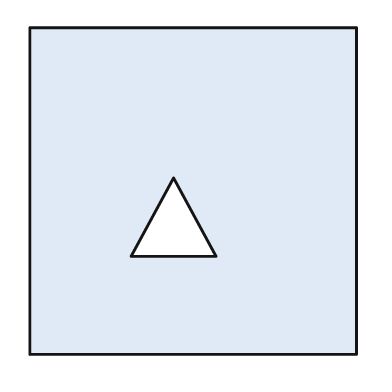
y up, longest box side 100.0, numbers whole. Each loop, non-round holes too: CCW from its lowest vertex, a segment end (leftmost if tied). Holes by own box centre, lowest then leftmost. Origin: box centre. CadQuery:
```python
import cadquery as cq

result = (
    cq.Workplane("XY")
    .moveTo(-50.0, -50.0)
    .lineTo(50.0, -50.0)
    .lineTo(50.0, 50.0)
    .lineTo(-50.0, 50.0)
    .close()
    .moveTo(-19.0, -20.0)
    .lineTo(7.0, -20.0)
    .lineTo(-6.0, 4.0)
    .close()
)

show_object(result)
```